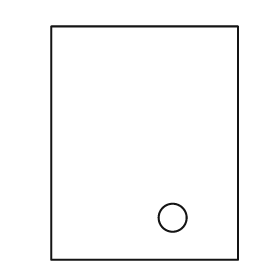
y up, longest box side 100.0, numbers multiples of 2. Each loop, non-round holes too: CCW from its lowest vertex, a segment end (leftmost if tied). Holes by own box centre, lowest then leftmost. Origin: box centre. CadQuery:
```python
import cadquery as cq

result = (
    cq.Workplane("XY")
    .moveTo(-40.0, -50.0)
    .lineTo(40.0, -50.0)
    .lineTo(40.0, 50.0)
    .lineTo(-40.0, 50.0)
    .close()
    .moveTo(12.0, -32.0)
    .circle(6.0)
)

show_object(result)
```